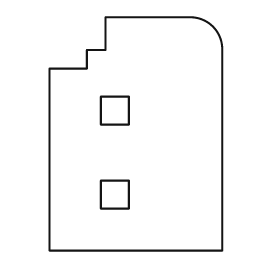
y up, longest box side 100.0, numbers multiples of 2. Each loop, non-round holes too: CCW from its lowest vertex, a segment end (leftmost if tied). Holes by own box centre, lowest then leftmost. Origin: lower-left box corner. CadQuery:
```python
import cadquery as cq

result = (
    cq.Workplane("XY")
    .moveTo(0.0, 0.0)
    .lineTo(74.0, 0.0)
    .lineTo(74.0, 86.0)
    .threePointArc((70.0, 96.0), (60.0, 100.0))
    .lineTo(24.0, 100.0)
    .lineTo(24.0, 86.0)
    .lineTo(16.0, 86.0)
    .lineTo(16.0, 78.0)
    .lineTo(0.0, 78.0)
    .close()
    .moveTo(22.0, 18.0)
    .lineTo(34.0, 18.0)
    .lineTo(34.0, 30.0)
    .lineTo(22.0, 30.0)
    .close()
    .moveTo(22.0, 54.0)
    .lineTo(34.0, 54.0)
    .lineTo(34.0, 66.0)
    .lineTo(22.0, 66.0)
    .close()
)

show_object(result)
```